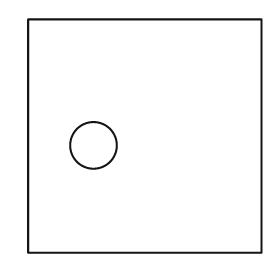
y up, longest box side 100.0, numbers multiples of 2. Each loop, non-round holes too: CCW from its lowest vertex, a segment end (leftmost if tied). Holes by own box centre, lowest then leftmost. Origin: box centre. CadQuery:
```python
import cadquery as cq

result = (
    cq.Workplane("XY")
    .moveTo(-50.0, -50.0)
    .lineTo(50.0, -50.0)
    .lineTo(50.0, 50.0)
    .lineTo(-50.0, 50.0)
    .close()
    .moveTo(-22.0, -4.0)
    .circle(10.0)
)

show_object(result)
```